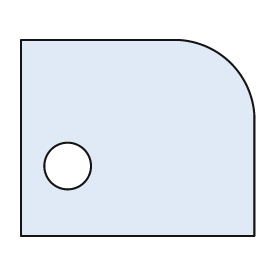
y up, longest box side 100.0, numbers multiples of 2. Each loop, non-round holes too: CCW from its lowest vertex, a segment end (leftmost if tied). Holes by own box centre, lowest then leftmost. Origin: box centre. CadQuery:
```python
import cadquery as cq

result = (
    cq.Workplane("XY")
    .moveTo(-50.0, -42.0)
    .lineTo(50.0, -42.0)
    .lineTo(50.0, 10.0)
    .threePointArc((40.0, 32.0), (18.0, 42.0))
    .lineTo(-50.0, 42.0)
    .close()
    .moveTo(-30.0, -12.0)
    .circle(10.0)
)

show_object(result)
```